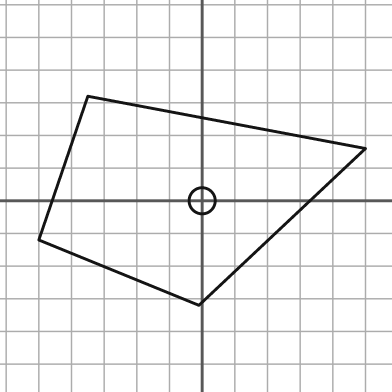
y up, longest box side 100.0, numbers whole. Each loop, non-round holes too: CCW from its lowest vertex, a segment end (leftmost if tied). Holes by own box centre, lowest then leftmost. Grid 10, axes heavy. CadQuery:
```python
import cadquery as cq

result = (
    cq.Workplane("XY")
    .moveTo(-1.0, -32.0)
    .lineTo(50.0, 16.0)
    .lineTo(-35.0, 32.0)
    .lineTo(-50.0, -12.0)
    .close()
    .moveTo(0.0, 0.0)
    .circle(4.0)
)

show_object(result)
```